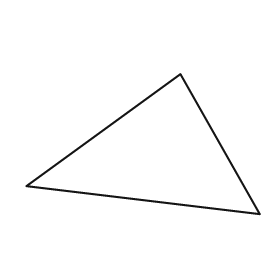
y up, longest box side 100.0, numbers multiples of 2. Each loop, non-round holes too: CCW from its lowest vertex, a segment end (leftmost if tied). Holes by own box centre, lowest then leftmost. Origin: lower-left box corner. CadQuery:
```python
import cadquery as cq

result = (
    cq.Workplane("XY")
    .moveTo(100.0, 0.0)
    .lineTo(66.0, 60.0)
    .lineTo(0.0, 12.0)
    .close()
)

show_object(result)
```